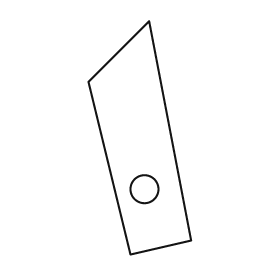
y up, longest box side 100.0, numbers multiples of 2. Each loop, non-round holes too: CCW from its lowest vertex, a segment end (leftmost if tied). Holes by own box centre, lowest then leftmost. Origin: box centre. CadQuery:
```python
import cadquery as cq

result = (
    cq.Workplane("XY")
    .moveTo(-4.0, -50.0)
    .lineTo(22.0, -44.0)
    .lineTo(4.0, 50.0)
    .lineTo(-22.0, 24.0)
    .close()
    .moveTo(2.0, -22.0)
    .circle(6.0)
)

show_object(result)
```